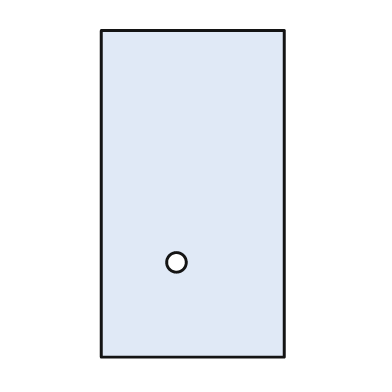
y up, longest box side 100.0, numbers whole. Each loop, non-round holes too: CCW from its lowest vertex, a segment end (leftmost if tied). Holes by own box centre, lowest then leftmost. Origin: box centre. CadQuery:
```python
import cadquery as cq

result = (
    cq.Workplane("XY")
    .moveTo(-28.0, -50.0)
    .lineTo(28.0, -50.0)
    .lineTo(28.0, 50.0)
    .lineTo(-28.0, 50.0)
    .close()
    .moveTo(-5.0, -21.0)
    .circle(3.0)
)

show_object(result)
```